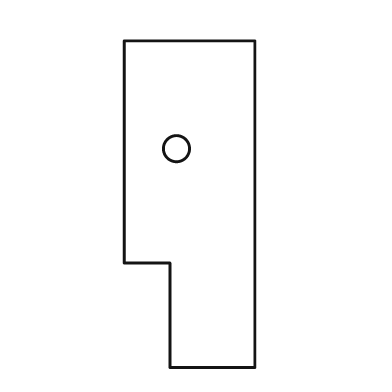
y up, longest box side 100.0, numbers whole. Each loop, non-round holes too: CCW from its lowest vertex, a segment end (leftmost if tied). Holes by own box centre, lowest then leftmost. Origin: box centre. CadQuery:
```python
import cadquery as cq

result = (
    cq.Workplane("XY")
    .moveTo(-6.0, -50.0)
    .lineTo(20.0, -50.0)
    .lineTo(20.0, 50.0)
    .lineTo(-20.0, 50.0)
    .lineTo(-20.0, -18.0)
    .lineTo(-6.0, -18.0)
    .close()
    .moveTo(-4.0, 17.0)
    .circle(4.0)
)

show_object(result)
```